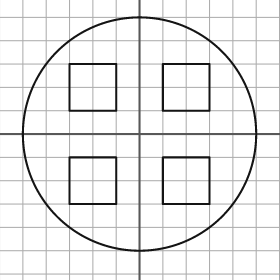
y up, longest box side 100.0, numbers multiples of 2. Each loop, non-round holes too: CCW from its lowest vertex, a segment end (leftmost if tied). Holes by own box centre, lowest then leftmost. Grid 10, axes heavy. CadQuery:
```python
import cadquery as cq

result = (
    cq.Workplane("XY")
    .moveTo(0.0, 0.0)
    .circle(50.0)
    .moveTo(-30.0, -30.0)
    .lineTo(-10.0, -30.0)
    .lineTo(-10.0, -10.0)
    .lineTo(-30.0, -10.0)
    .close()
    .moveTo(10.0, -30.0)
    .lineTo(30.0, -30.0)
    .lineTo(30.0, -10.0)
    .lineTo(10.0, -10.0)
    .close()
    .moveTo(-30.0, 10.0)
    .lineTo(-10.0, 10.0)
    .lineTo(-10.0, 30.0)
    .lineTo(-30.0, 30.0)
    .close()
    .moveTo(10.0, 10.0)
    .lineTo(30.0, 10.0)
    .lineTo(30.0, 30.0)
    .lineTo(10.0, 30.0)
    .close()
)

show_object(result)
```